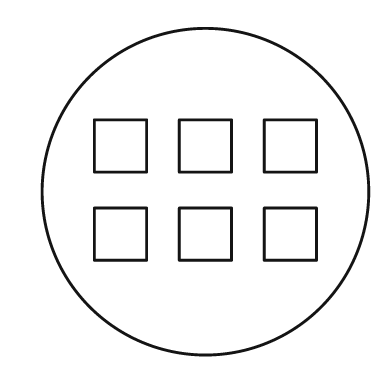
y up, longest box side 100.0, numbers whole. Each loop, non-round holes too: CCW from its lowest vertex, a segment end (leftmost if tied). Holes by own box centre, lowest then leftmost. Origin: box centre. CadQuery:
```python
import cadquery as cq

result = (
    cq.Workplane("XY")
    .moveTo(0.0, 0.0)
    .circle(50.0)
    .moveTo(-34.0, -21.0)
    .lineTo(-18.0, -21.0)
    .lineTo(-18.0, -5.0)
    .lineTo(-34.0, -5.0)
    .close()
    .moveTo(-8.0, -21.0)
    .lineTo(8.0, -21.0)
    .lineTo(8.0, -5.0)
    .lineTo(-8.0, -5.0)
    .close()
    .moveTo(18.0, -21.0)
    .lineTo(34.0, -21.0)
    .lineTo(34.0, -5.0)
    .lineTo(18.0, -5.0)
    .close()
    .moveTo(-34.0, 6.0)
    .lineTo(-18.0, 6.0)
    .lineTo(-18.0, 22.0)
    .lineTo(-34.0, 22.0)
    .close()
    .moveTo(-8.0, 6.0)
    .lineTo(8.0, 6.0)
    .lineTo(8.0, 22.0)
    .lineTo(-8.0, 22.0)
    .close()
    .moveTo(18.0, 6.0)
    .lineTo(34.0, 6.0)
    .lineTo(34.0, 22.0)
    .lineTo(18.0, 22.0)
    .close()
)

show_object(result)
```